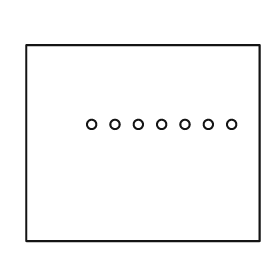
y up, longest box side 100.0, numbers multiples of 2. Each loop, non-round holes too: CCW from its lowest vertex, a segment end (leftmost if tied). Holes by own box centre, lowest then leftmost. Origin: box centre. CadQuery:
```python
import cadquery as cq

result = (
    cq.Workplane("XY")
    .moveTo(-50.0, -42.0)
    .lineTo(50.0, -42.0)
    .lineTo(50.0, 42.0)
    .lineTo(-50.0, 42.0)
    .close()
    .moveTo(-22.0, 8.0)
    .circle(2.0)
    .moveTo(-12.0, 8.0)
    .circle(2.0)
    .moveTo(-2.0, 8.0)
    .circle(2.0)
    .moveTo(8.0, 8.0)
    .circle(2.0)
    .moveTo(18.0, 8.0)
    .circle(2.0)
    .moveTo(28.0, 8.0)
    .circle(2.0)
    .moveTo(38.0, 8.0)
    .circle(2.0)
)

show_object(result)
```